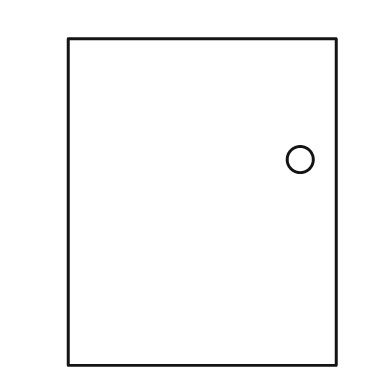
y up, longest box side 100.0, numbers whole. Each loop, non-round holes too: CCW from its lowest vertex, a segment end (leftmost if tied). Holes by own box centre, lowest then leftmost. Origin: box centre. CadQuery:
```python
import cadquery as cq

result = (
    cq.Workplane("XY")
    .moveTo(-41.0, -50.0)
    .lineTo(41.0, -50.0)
    .lineTo(41.0, 50.0)
    .lineTo(-41.0, 50.0)
    .close()
    .moveTo(30.0, 13.0)
    .circle(4.0)
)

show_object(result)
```